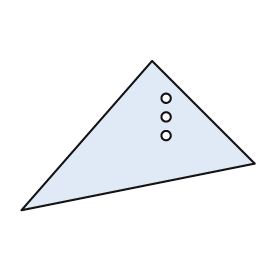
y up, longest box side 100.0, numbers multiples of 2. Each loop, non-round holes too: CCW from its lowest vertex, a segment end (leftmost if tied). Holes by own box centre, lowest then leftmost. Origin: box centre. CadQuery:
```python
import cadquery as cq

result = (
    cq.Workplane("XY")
    .moveTo(-50.0, -32.0)
    .lineTo(50.0, -12.0)
    .lineTo(6.0, 32.0)
    .close()
    .moveTo(12.0, 0.0)
    .circle(2.0)
    .moveTo(12.0, 8.0)
    .circle(2.0)
    .moveTo(12.0, 16.0)
    .circle(2.0)
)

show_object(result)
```